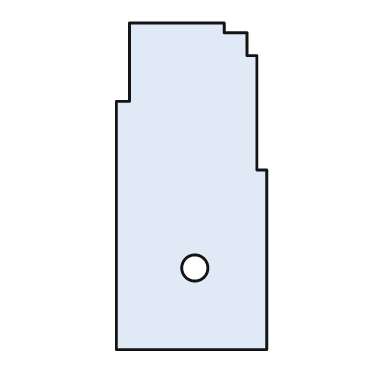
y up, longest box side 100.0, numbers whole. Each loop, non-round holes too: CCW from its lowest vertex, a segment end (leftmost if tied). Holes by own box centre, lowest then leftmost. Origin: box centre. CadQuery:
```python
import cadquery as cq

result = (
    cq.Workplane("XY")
    .moveTo(-23.0, -50.0)
    .lineTo(23.0, -50.0)
    .lineTo(23.0, 5.0)
    .lineTo(20.0, 5.0)
    .lineTo(20.0, 40.0)
    .lineTo(17.0, 40.0)
    .lineTo(17.0, 47.0)
    .lineTo(10.0, 47.0)
    .lineTo(10.0, 50.0)
    .lineTo(-19.0, 50.0)
    .lineTo(-19.0, 26.0)
    .lineTo(-23.0, 26.0)
    .close()
    .moveTo(1.0, -25.0)
    .circle(4.0)
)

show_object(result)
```